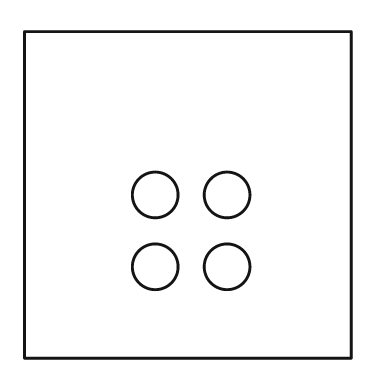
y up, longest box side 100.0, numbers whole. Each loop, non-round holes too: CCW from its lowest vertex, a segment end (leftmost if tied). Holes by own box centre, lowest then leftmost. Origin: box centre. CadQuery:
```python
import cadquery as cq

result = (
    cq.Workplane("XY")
    .moveTo(-50.0, -50.0)
    .lineTo(50.0, -50.0)
    .lineTo(50.0, 50.0)
    .lineTo(-50.0, 50.0)
    .close()
    .moveTo(-10.0, -22.0)
    .circle(7.0)
    .moveTo(12.0, -22.0)
    .circle(7.0)
    .moveTo(-10.0, 0.0)
    .circle(7.0)
    .moveTo(12.0, 0.0)
    .circle(7.0)
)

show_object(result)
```